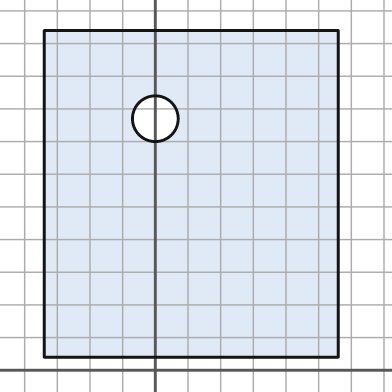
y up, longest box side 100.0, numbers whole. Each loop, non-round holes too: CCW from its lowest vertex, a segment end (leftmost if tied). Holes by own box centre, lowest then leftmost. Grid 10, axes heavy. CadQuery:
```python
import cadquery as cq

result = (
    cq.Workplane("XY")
    .moveTo(-34.0, 4.0)
    .lineTo(56.0, 4.0)
    .lineTo(56.0, 104.0)
    .lineTo(-34.0, 104.0)
    .close()
    .moveTo(0.0, 77.0)
    .circle(7.0)
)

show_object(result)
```